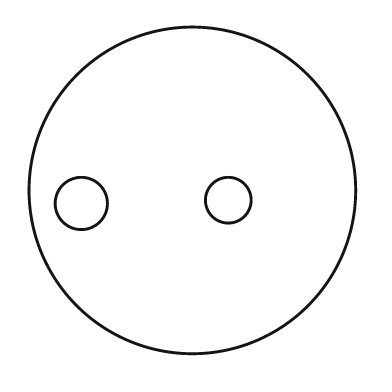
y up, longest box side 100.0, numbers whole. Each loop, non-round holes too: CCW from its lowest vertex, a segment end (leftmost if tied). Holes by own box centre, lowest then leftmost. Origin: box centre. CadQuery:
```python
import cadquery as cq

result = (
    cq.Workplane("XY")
    .moveTo(0.0, 0.0)
    .circle(50.0)
    .moveTo(-34.0, -4.0)
    .circle(8.0)
    .moveTo(11.0, -3.0)
    .circle(7.0)
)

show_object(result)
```